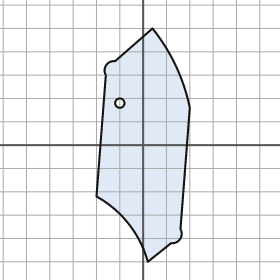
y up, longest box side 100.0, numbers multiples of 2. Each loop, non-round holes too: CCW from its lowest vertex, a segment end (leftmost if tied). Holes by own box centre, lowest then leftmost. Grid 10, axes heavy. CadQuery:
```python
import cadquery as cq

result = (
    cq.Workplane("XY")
    .moveTo(2.0, -50.0)
    .lineTo(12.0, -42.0)
    .threePointArc((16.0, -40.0), (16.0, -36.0))
    .lineTo(20.0, 16.0)
    .threePointArc((14.0, 34.0), (4.0, 50.0))
    .lineTo(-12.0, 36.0)
    .threePointArc((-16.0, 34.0), (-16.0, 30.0))
    .lineTo(-20.0, -22.0)
    .threePointArc((-6.0, -34.0), (2.0, -50.0))
    .close()
    .moveTo(-10.0, 18.0)
    .circle(2.0)
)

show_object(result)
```